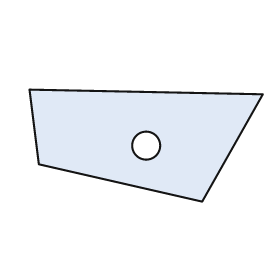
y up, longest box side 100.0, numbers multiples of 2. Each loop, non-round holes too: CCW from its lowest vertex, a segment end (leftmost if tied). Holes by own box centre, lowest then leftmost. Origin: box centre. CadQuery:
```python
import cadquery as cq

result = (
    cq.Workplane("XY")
    .moveTo(24.0, -24.0)
    .lineTo(50.0, 22.0)
    .lineTo(-50.0, 24.0)
    .lineTo(-46.0, -8.0)
    .close()
    .moveTo(0.0, 0.0)
    .circle(6.0)
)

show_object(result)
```